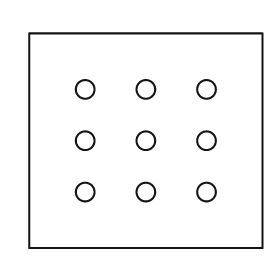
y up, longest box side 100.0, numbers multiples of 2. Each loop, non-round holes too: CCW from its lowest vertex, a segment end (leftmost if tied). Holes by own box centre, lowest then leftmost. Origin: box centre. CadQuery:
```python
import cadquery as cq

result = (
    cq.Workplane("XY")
    .moveTo(-50.0, -46.0)
    .lineTo(50.0, -46.0)
    .lineTo(50.0, 46.0)
    .lineTo(-50.0, 46.0)
    .close()
    .moveTo(-26.0, -22.0)
    .circle(4.0)
    .moveTo(0.0, -22.0)
    .circle(4.0)
    .moveTo(26.0, -22.0)
    .circle(4.0)
    .moveTo(-26.0, 0.0)
    .circle(4.0)
    .moveTo(0.0, 0.0)
    .circle(4.0)
    .moveTo(26.0, 0.0)
    .circle(4.0)
    .moveTo(-26.0, 22.0)
    .circle(4.0)
    .moveTo(0.0, 22.0)
    .circle(4.0)
    .moveTo(26.0, 22.0)
    .circle(4.0)
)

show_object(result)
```